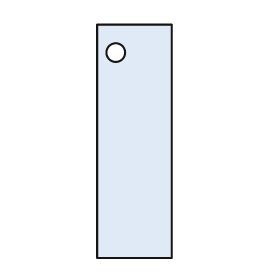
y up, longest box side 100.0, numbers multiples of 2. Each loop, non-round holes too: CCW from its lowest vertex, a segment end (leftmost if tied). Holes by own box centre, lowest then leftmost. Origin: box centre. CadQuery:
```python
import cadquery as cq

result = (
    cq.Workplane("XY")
    .moveTo(-16.0, -50.0)
    .lineTo(16.0, -50.0)
    .lineTo(16.0, 50.0)
    .lineTo(-16.0, 50.0)
    .close()
    .moveTo(-8.0, 38.0)
    .circle(4.0)
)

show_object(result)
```